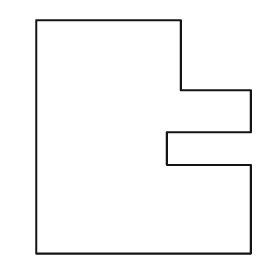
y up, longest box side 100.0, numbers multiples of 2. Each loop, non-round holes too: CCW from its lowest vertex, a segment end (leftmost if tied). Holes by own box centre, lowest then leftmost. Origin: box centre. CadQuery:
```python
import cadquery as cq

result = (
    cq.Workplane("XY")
    .moveTo(-46.0, -50.0)
    .lineTo(46.0, -50.0)
    .lineTo(46.0, -12.0)
    .lineTo(10.0, -12.0)
    .lineTo(10.0, 2.0)
    .lineTo(46.0, 2.0)
    .lineTo(46.0, 20.0)
    .lineTo(16.0, 20.0)
    .lineTo(16.0, 50.0)
    .lineTo(-46.0, 50.0)
    .close()
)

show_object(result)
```